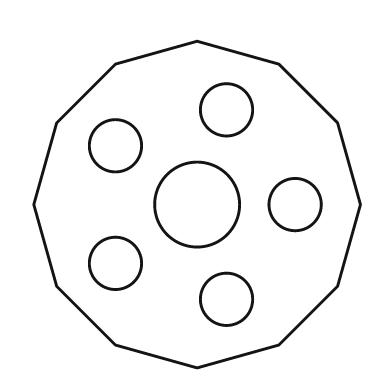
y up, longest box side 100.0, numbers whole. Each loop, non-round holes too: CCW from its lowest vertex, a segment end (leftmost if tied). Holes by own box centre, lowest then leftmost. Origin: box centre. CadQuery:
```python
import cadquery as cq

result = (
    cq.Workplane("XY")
    .moveTo(0.0, -50.0)
    .lineTo(25.0, -43.0)
    .lineTo(43.0, -25.0)
    .lineTo(50.0, 0.0)
    .lineTo(43.0, 25.0)
    .lineTo(25.0, 43.0)
    .lineTo(0.0, 50.0)
    .lineTo(-25.0, 43.0)
    .lineTo(-43.0, 25.0)
    .lineTo(-50.0, 0.0)
    .lineTo(-43.0, -25.0)
    .lineTo(-25.0, -43.0)
    .close()
    .moveTo(9.0, -29.0)
    .circle(8.0)
    .moveTo(-25.0, -18.0)
    .circle(8.0)
    .moveTo(0.0, 0.0)
    .circle(13.0)
    .moveTo(30.0, 0.0)
    .circle(8.0)
    .moveTo(-25.0, 18.0)
    .circle(8.0)
    .moveTo(9.0, 29.0)
    .circle(8.0)
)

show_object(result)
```